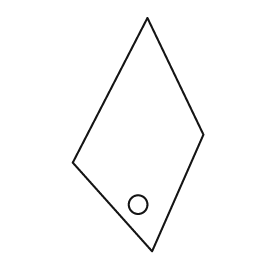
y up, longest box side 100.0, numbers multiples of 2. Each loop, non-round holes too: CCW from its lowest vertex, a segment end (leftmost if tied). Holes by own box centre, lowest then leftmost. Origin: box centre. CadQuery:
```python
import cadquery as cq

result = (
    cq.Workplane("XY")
    .moveTo(6.0, -50.0)
    .lineTo(28.0, 0.0)
    .lineTo(4.0, 50.0)
    .lineTo(-28.0, -12.0)
    .close()
    .moveTo(0.0, -30.0)
    .circle(4.0)
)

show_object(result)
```